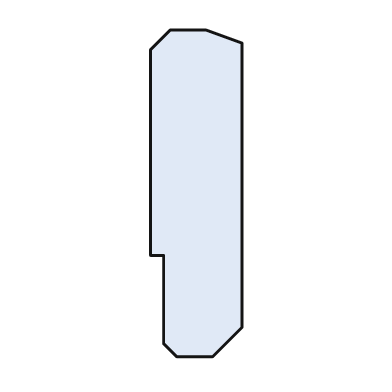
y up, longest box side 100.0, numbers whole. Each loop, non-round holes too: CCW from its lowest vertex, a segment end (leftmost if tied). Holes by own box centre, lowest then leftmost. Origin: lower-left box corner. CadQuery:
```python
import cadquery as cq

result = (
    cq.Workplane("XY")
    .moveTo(8.0, 0.0)
    .lineTo(19.0, 0.0)
    .lineTo(28.0, 9.0)
    .lineTo(28.0, 96.0)
    .lineTo(17.0, 100.0)
    .lineTo(6.0, 100.0)
    .lineTo(0.0, 94.0)
    .lineTo(0.0, 31.0)
    .lineTo(4.0, 31.0)
    .lineTo(4.0, 4.0)
    .close()
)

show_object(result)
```